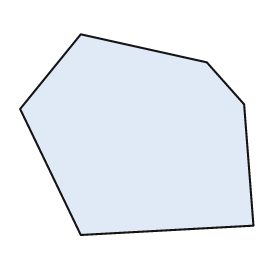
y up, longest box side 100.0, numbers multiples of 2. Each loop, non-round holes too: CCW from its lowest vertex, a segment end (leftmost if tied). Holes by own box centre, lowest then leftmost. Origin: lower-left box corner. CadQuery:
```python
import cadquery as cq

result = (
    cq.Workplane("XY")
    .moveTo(26.0, 0.0)
    .lineTo(100.0, 4.0)
    .lineTo(96.0, 56.0)
    .lineTo(80.0, 74.0)
    .lineTo(26.0, 86.0)
    .lineTo(0.0, 54.0)
    .close()
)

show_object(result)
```